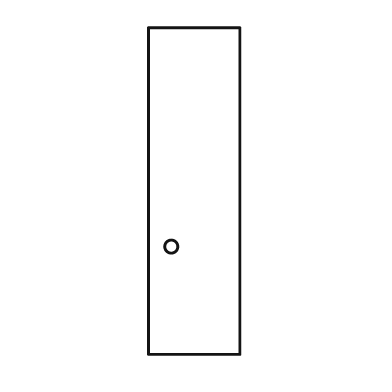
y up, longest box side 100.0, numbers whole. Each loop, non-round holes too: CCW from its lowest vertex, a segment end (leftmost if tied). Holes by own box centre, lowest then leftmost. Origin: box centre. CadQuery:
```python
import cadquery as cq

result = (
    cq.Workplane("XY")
    .moveTo(-14.0, -50.0)
    .lineTo(14.0, -50.0)
    .lineTo(14.0, 50.0)
    .lineTo(-14.0, 50.0)
    .close()
    .moveTo(-7.0, -17.0)
    .circle(2.0)
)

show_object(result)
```